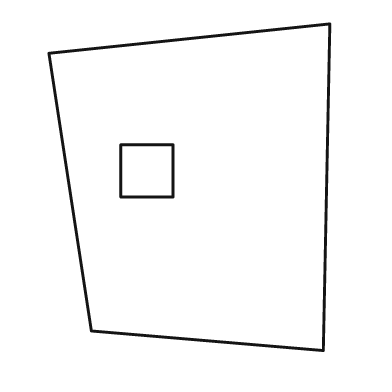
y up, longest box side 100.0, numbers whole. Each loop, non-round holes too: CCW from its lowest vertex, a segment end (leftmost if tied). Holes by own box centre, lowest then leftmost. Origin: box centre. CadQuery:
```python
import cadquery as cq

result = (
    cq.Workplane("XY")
    .moveTo(41.0, -50.0)
    .lineTo(43.0, 50.0)
    .lineTo(-43.0, 41.0)
    .lineTo(-30.0, -44.0)
    .close()
    .moveTo(-21.0, -3.0)
    .lineTo(-5.0, -3.0)
    .lineTo(-5.0, 13.0)
    .lineTo(-21.0, 13.0)
    .close()
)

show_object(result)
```